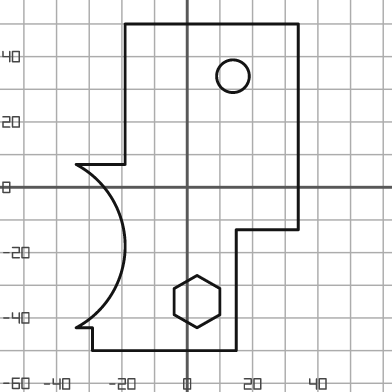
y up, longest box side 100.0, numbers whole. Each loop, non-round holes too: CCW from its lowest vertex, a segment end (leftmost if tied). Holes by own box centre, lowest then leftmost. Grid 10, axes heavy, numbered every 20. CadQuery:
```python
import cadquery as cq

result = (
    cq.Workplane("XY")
    .moveTo(-29.0, -50.0)
    .lineTo(15.0, -50.0)
    .lineTo(15.0, -13.0)
    .lineTo(34.0, -13.0)
    .lineTo(34.0, 50.0)
    .lineTo(-19.0, 50.0)
    .lineTo(-19.0, 7.0)
    .lineTo(-34.0, 7.0)
    .threePointArc((-19.0, -18.0), (-34.0, -43.0))
    .lineTo(-29.0, -43.0)
    .close()
    .moveTo(3.0, -43.0)
    .lineTo(10.0, -39.0)
    .lineTo(10.0, -31.0)
    .lineTo(3.0, -27.0)
    .lineTo(-4.0, -31.0)
    .lineTo(-4.0, -39.0)
    .close()
    .moveTo(14.0, 34.0)
    .circle(5.0)
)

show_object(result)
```